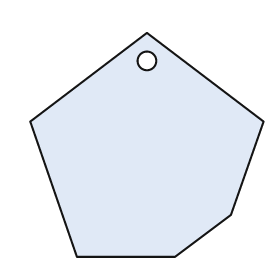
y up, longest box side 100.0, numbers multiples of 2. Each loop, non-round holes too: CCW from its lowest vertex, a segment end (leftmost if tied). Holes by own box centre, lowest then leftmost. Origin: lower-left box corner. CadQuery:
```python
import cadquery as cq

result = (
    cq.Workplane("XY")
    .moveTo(20.0, 0.0)
    .lineTo(62.0, 0.0)
    .lineTo(86.0, 18.0)
    .lineTo(100.0, 58.0)
    .lineTo(50.0, 96.0)
    .lineTo(0.0, 58.0)
    .close()
    .moveTo(50.0, 84.0)
    .circle(4.0)
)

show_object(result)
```